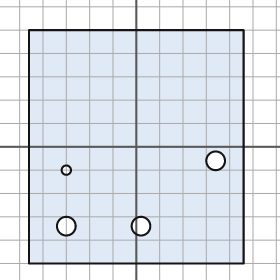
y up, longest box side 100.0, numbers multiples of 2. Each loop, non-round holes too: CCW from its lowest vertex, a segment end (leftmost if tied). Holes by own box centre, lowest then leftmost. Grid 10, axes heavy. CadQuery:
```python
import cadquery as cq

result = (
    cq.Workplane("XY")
    .moveTo(-46.0, -50.0)
    .lineTo(46.0, -50.0)
    .lineTo(46.0, 50.0)
    .lineTo(-46.0, 50.0)
    .close()
    .moveTo(-30.0, -34.0)
    .circle(4.0)
    .moveTo(2.0, -34.0)
    .circle(4.0)
    .moveTo(-30.0, -10.0)
    .circle(2.0)
    .moveTo(34.0, -6.0)
    .circle(4.0)
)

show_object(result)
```